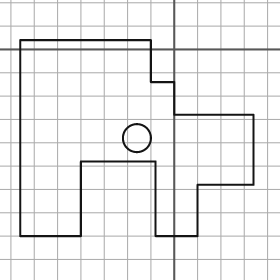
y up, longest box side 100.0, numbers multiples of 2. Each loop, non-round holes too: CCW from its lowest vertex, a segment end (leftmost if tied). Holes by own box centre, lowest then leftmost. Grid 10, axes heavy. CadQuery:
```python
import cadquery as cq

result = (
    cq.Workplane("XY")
    .moveTo(-66.0, -80.0)
    .lineTo(-40.0, -80.0)
    .lineTo(-40.0, -48.0)
    .lineTo(-8.0, -48.0)
    .lineTo(-8.0, -80.0)
    .lineTo(10.0, -80.0)
    .lineTo(10.0, -58.0)
    .lineTo(34.0, -58.0)
    .lineTo(34.0, -28.0)
    .lineTo(0.0, -28.0)
    .lineTo(0.0, -14.0)
    .lineTo(-10.0, -14.0)
    .lineTo(-10.0, 4.0)
    .lineTo(-66.0, 4.0)
    .close()
    .moveTo(-16.0, -38.0)
    .circle(6.0)
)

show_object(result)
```